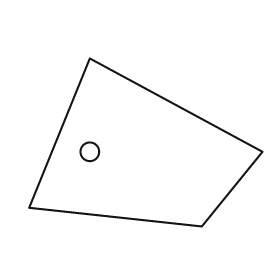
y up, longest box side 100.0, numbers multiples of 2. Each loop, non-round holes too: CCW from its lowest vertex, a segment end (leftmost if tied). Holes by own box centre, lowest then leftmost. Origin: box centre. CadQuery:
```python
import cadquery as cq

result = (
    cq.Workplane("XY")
    .moveTo(24.0, -36.0)
    .lineTo(50.0, -4.0)
    .lineTo(-24.0, 36.0)
    .lineTo(-50.0, -28.0)
    .close()
    .moveTo(-24.0, -4.0)
    .circle(4.0)
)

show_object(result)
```